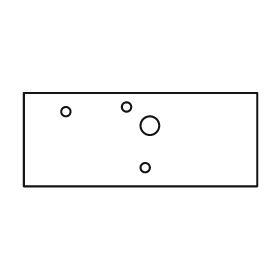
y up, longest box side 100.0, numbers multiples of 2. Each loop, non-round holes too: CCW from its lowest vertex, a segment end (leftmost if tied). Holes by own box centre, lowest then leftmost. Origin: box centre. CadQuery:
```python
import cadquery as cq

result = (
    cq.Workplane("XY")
    .moveTo(-50.0, -20.0)
    .lineTo(50.0, -20.0)
    .lineTo(50.0, 20.0)
    .lineTo(-50.0, 20.0)
    .close()
    .moveTo(2.0, -12.0)
    .circle(2.0)
    .moveTo(4.0, 6.0)
    .circle(4.0)
    .moveTo(-32.0, 12.0)
    .circle(2.0)
    .moveTo(-6.0, 14.0)
    .circle(2.0)
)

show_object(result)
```